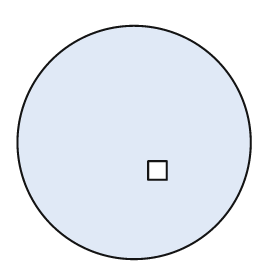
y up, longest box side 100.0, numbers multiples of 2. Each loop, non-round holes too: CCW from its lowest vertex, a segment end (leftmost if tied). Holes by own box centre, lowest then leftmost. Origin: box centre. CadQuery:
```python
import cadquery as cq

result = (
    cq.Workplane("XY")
    .moveTo(0.0, 0.0)
    .circle(50.0)
    .moveTo(6.0, -16.0)
    .lineTo(14.0, -16.0)
    .lineTo(14.0, -8.0)
    .lineTo(6.0, -8.0)
    .close()
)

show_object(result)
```